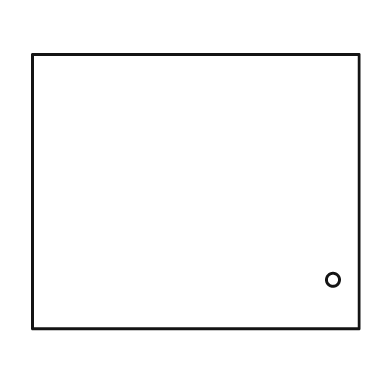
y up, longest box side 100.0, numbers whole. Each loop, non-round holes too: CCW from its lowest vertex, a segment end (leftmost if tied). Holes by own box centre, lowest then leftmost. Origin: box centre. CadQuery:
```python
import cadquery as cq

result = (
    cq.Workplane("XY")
    .moveTo(-50.0, -42.0)
    .lineTo(50.0, -42.0)
    .lineTo(50.0, 42.0)
    .lineTo(-50.0, 42.0)
    .close()
    .moveTo(42.0, -27.0)
    .circle(2.0)
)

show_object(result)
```